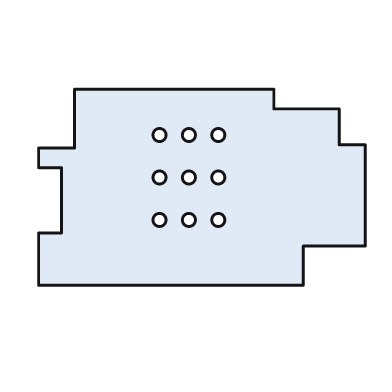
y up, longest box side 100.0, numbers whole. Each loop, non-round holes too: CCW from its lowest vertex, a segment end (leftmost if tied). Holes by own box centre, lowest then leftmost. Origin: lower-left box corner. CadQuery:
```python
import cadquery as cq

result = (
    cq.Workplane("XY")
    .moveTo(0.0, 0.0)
    .lineTo(81.0, 0.0)
    .lineTo(81.0, 12.0)
    .lineTo(100.0, 12.0)
    .lineTo(100.0, 43.0)
    .lineTo(92.0, 43.0)
    .lineTo(92.0, 54.0)
    .lineTo(72.0, 54.0)
    .lineTo(72.0, 60.0)
    .lineTo(11.0, 60.0)
    .lineTo(11.0, 42.0)
    .lineTo(0.0, 42.0)
    .lineTo(0.0, 36.0)
    .lineTo(7.0, 36.0)
    .lineTo(7.0, 16.0)
    .lineTo(0.0, 16.0)
    .close()
    .moveTo(37.0, 20.0)
    .circle(2.0)
    .moveTo(46.0, 20.0)
    .circle(2.0)
    .moveTo(55.0, 20.0)
    .circle(2.0)
    .moveTo(37.0, 33.0)
    .circle(2.0)
    .moveTo(46.0, 33.0)
    .circle(2.0)
    .moveTo(55.0, 33.0)
    .circle(2.0)
    .moveTo(37.0, 46.0)
    .circle(2.0)
    .moveTo(46.0, 46.0)
    .circle(2.0)
    .moveTo(55.0, 46.0)
    .circle(2.0)
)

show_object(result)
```